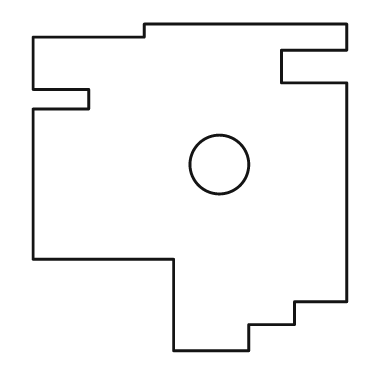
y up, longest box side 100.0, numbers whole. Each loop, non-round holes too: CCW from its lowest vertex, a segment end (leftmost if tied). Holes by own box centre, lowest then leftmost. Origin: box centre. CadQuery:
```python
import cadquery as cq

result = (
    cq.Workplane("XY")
    .moveTo(-5.0, -50.0)
    .lineTo(18.0, -50.0)
    .lineTo(18.0, -42.0)
    .lineTo(32.0, -42.0)
    .lineTo(32.0, -35.0)
    .lineTo(48.0, -35.0)
    .lineTo(48.0, 32.0)
    .lineTo(28.0, 32.0)
    .lineTo(28.0, 42.0)
    .lineTo(48.0, 42.0)
    .lineTo(48.0, 50.0)
    .lineTo(-14.0, 50.0)
    .lineTo(-14.0, 46.0)
    .lineTo(-48.0, 46.0)
    .lineTo(-48.0, 30.0)
    .lineTo(-31.0, 30.0)
    .lineTo(-31.0, 24.0)
    .lineTo(-48.0, 24.0)
    .lineTo(-48.0, -22.0)
    .lineTo(-5.0, -22.0)
    .close()
    .moveTo(9.0, 7.0)
    .circle(9.0)
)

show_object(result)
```